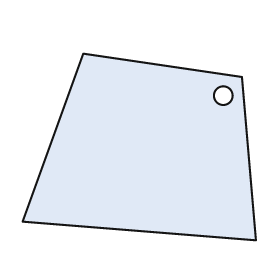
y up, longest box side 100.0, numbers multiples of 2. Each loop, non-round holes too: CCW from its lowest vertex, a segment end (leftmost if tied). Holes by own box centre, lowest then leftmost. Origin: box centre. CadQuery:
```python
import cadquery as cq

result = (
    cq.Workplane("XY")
    .moveTo(50.0, -40.0)
    .lineTo(44.0, 30.0)
    .lineTo(-24.0, 40.0)
    .lineTo(-50.0, -32.0)
    .close()
    .moveTo(36.0, 22.0)
    .circle(4.0)
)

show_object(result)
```